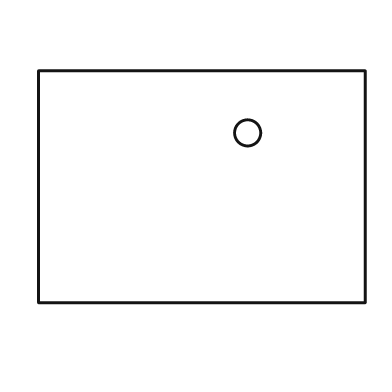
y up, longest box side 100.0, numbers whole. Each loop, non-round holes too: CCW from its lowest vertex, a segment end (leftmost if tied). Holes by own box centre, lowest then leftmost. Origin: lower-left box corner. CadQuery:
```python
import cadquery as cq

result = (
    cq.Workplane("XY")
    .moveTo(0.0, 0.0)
    .lineTo(100.0, 0.0)
    .lineTo(100.0, 71.0)
    .lineTo(0.0, 71.0)
    .close()
    .moveTo(64.0, 52.0)
    .circle(4.0)
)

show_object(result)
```